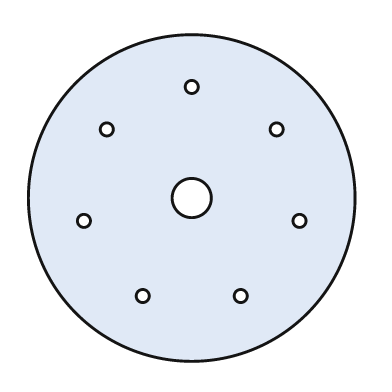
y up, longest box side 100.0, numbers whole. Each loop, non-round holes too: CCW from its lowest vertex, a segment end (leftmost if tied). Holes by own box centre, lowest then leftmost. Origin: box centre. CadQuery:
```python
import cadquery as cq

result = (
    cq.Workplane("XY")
    .moveTo(0.0, 0.0)
    .circle(50.0)
    .moveTo(-15.0, -30.0)
    .circle(2.0)
    .moveTo(15.0, -30.0)
    .circle(2.0)
    .moveTo(-33.0, -7.0)
    .circle(2.0)
    .moveTo(33.0, -7.0)
    .circle(2.0)
    .moveTo(0.0, 0.0)
    .circle(6.0)
    .moveTo(-26.0, 21.0)
    .circle(2.0)
    .moveTo(26.0, 21.0)
    .circle(2.0)
    .moveTo(0.0, 34.0)
    .circle(2.0)
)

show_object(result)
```